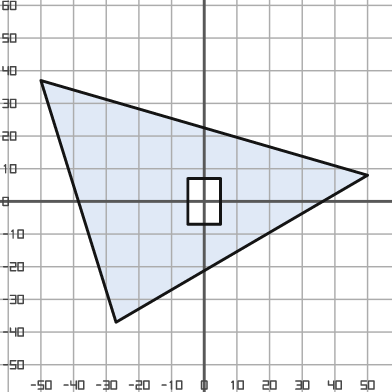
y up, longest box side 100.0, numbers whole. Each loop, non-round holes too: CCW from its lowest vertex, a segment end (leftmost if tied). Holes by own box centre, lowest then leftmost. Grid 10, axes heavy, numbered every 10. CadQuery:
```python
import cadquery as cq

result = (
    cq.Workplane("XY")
    .moveTo(-27.0, -37.0)
    .lineTo(50.0, 8.0)
    .lineTo(-50.0, 37.0)
    .close()
    .moveTo(-5.0, -7.0)
    .lineTo(5.0, -7.0)
    .lineTo(5.0, 7.0)
    .lineTo(-5.0, 7.0)
    .close()
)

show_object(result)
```